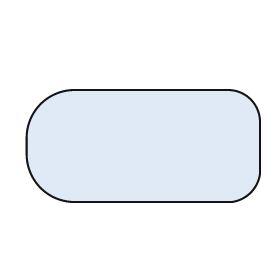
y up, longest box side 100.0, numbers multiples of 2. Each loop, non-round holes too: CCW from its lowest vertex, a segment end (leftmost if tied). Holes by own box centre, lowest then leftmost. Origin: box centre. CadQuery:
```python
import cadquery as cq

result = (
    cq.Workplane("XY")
    .moveTo(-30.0, -24.0)
    .lineTo(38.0, -24.0)
    .threePointArc((46.0, -20.0), (50.0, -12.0))
    .lineTo(50.0, 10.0)
    .threePointArc((46.0, 20.0), (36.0, 24.0))
    .lineTo(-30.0, 24.0)
    .threePointArc((-44.0, 18.0), (-50.0, 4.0))
    .lineTo(-50.0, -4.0)
    .threePointArc((-44.0, -18.0), (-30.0, -24.0))
    .close()
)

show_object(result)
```